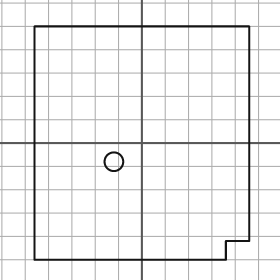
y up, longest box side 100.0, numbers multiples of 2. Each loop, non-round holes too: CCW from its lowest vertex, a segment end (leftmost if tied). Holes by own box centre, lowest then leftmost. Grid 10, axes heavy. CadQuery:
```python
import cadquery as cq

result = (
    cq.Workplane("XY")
    .moveTo(-46.0, -50.0)
    .lineTo(36.0, -50.0)
    .lineTo(36.0, -42.0)
    .lineTo(46.0, -42.0)
    .lineTo(46.0, 50.0)
    .lineTo(-46.0, 50.0)
    .close()
    .moveTo(-12.0, -8.0)
    .circle(4.0)
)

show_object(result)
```